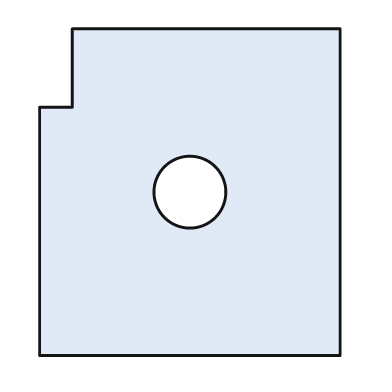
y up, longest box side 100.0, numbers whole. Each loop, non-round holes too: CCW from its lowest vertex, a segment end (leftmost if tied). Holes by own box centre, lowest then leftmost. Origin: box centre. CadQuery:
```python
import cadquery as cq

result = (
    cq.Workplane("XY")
    .moveTo(-46.0, -50.0)
    .lineTo(46.0, -50.0)
    .lineTo(46.0, 50.0)
    .lineTo(-36.0, 50.0)
    .lineTo(-36.0, 26.0)
    .lineTo(-46.0, 26.0)
    .close()
    .moveTo(0.0, 0.0)
    .circle(11.0)
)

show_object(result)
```